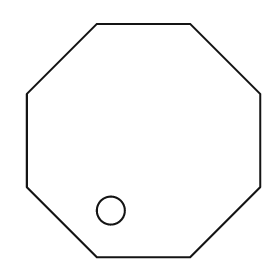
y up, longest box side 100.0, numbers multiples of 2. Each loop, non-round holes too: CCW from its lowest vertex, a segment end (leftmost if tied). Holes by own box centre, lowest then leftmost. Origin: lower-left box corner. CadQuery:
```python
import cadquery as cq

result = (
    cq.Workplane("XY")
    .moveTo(30.0, 0.0)
    .lineTo(70.0, 0.0)
    .lineTo(100.0, 30.0)
    .lineTo(100.0, 70.0)
    .lineTo(70.0, 100.0)
    .lineTo(30.0, 100.0)
    .lineTo(0.0, 70.0)
    .lineTo(0.0, 30.0)
    .close()
    .moveTo(36.0, 20.0)
    .circle(6.0)
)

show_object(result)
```